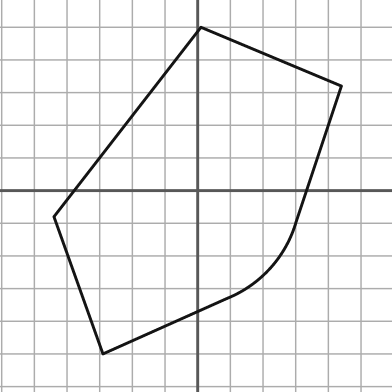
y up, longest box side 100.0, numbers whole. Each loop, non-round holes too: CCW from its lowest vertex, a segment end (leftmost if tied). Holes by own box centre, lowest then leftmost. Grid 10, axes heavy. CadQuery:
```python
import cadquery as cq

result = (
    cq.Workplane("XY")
    .moveTo(-29.0, -50.0)
    .lineTo(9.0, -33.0)
    .threePointArc((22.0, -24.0), (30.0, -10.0))
    .lineTo(44.0, 32.0)
    .lineTo(1.0, 50.0)
    .lineTo(-44.0, -8.0)
    .close()
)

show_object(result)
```